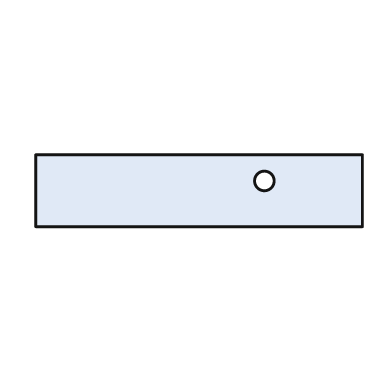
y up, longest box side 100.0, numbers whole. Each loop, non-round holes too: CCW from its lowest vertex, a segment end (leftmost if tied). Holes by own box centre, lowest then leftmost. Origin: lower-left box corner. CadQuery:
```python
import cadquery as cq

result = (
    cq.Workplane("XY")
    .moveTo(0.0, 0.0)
    .lineTo(100.0, 0.0)
    .lineTo(100.0, 22.0)
    .lineTo(0.0, 22.0)
    .close()
    .moveTo(70.0, 14.0)
    .circle(3.0)
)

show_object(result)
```